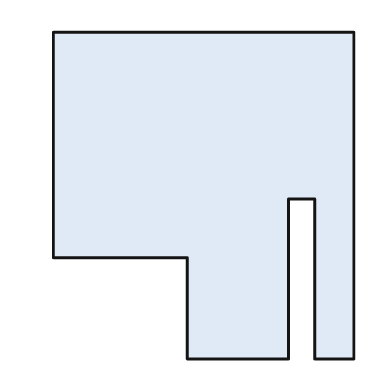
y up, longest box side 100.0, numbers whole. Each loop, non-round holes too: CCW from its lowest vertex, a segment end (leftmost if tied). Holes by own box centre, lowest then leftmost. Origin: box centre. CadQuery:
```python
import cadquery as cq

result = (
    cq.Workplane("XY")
    .moveTo(-5.0, -50.0)
    .lineTo(26.0, -50.0)
    .lineTo(26.0, -1.0)
    .lineTo(34.0, -1.0)
    .lineTo(34.0, -50.0)
    .lineTo(46.0, -50.0)
    .lineTo(46.0, 50.0)
    .lineTo(-46.0, 50.0)
    .lineTo(-46.0, -19.0)
    .lineTo(-5.0, -19.0)
    .close()
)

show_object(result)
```